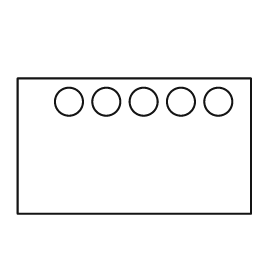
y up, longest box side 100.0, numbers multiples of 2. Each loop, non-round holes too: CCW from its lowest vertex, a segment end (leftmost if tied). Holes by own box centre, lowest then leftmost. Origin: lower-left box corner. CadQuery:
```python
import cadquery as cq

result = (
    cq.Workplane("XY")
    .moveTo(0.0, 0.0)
    .lineTo(100.0, 0.0)
    .lineTo(100.0, 58.0)
    .lineTo(0.0, 58.0)
    .close()
    .moveTo(22.0, 48.0)
    .circle(6.0)
    .moveTo(38.0, 48.0)
    .circle(6.0)
    .moveTo(54.0, 48.0)
    .circle(6.0)
    .moveTo(70.0, 48.0)
    .circle(6.0)
    .moveTo(86.0, 48.0)
    .circle(6.0)
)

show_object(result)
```